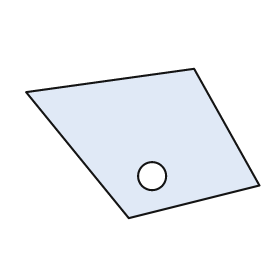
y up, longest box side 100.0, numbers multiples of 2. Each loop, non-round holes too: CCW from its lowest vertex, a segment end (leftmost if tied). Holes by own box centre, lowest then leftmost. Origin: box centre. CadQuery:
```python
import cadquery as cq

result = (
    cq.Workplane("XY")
    .moveTo(-6.0, -32.0)
    .lineTo(50.0, -18.0)
    .lineTo(22.0, 32.0)
    .lineTo(-50.0, 22.0)
    .close()
    .moveTo(4.0, -14.0)
    .circle(6.0)
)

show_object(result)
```